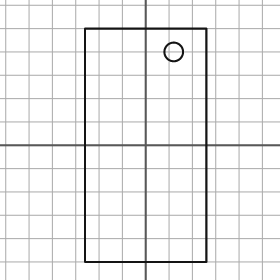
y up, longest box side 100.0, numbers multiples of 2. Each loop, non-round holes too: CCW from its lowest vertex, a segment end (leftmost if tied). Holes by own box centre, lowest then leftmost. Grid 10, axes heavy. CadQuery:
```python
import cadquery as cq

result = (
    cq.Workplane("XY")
    .moveTo(-26.0, -50.0)
    .lineTo(26.0, -50.0)
    .lineTo(26.0, 50.0)
    .lineTo(-26.0, 50.0)
    .close()
    .moveTo(12.0, 40.0)
    .circle(4.0)
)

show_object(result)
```